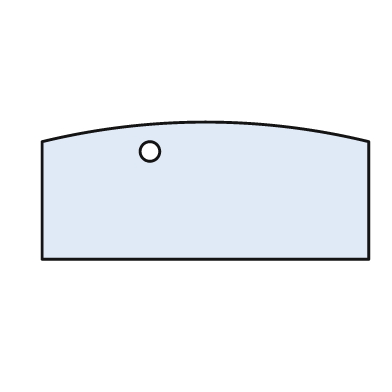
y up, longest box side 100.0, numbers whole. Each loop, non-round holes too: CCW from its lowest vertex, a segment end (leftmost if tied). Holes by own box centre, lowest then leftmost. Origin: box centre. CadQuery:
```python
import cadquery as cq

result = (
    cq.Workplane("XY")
    .moveTo(-50.0, -21.0)
    .lineTo(50.0, -21.0)
    .lineTo(50.0, 15.0)
    .threePointArc((0.0, 21.0), (-50.0, 15.0))
    .close()
    .moveTo(-17.0, 12.0)
    .circle(3.0)
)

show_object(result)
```